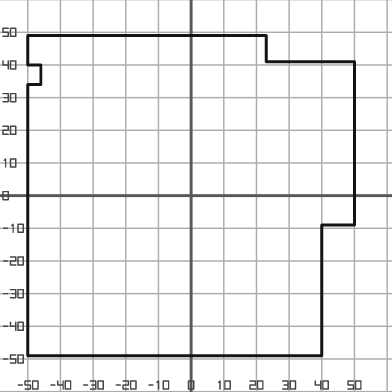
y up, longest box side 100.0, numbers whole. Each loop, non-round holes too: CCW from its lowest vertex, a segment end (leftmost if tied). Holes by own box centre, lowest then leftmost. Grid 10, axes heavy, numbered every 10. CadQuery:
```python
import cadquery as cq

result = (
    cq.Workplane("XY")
    .moveTo(-50.0, -49.0)
    .lineTo(40.0, -49.0)
    .lineTo(40.0, -9.0)
    .lineTo(50.0, -9.0)
    .lineTo(50.0, 41.0)
    .lineTo(23.0, 41.0)
    .lineTo(23.0, 49.0)
    .lineTo(-50.0, 49.0)
    .lineTo(-50.0, 40.0)
    .lineTo(-46.0, 40.0)
    .lineTo(-46.0, 34.0)
    .lineTo(-50.0, 34.0)
    .close()
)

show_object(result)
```